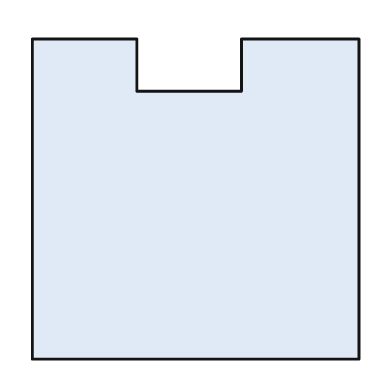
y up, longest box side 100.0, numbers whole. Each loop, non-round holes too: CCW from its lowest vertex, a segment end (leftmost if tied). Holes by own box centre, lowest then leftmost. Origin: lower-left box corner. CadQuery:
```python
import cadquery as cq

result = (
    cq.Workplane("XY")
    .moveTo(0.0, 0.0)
    .lineTo(100.0, 0.0)
    .lineTo(100.0, 98.0)
    .lineTo(64.0, 98.0)
    .lineTo(64.0, 82.0)
    .lineTo(32.0, 82.0)
    .lineTo(32.0, 98.0)
    .lineTo(0.0, 98.0)
    .close()
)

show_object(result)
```